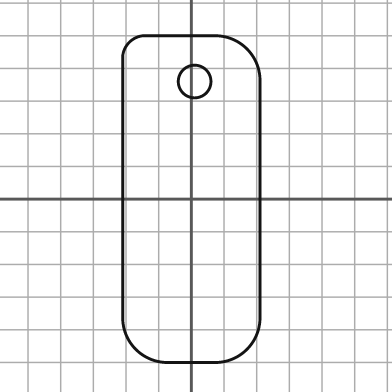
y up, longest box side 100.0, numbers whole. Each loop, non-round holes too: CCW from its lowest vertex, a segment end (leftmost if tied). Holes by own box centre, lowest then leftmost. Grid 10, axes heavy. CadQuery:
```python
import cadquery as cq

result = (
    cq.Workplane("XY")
    .moveTo(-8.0, -50.0)
    .lineTo(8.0, -50.0)
    .threePointArc((17.0, -46.0), (21.0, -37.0))
    .lineTo(21.0, 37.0)
    .threePointArc((17.0, 46.0), (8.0, 50.0))
    .lineTo(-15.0, 50.0)
    .threePointArc((-19.0, 48.0), (-21.0, 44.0))
    .lineTo(-21.0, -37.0)
    .threePointArc((-17.0, -46.0), (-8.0, -50.0))
    .close()
    .moveTo(1.0, 36.0)
    .circle(5.0)
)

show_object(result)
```